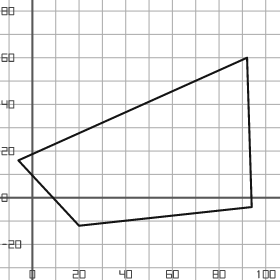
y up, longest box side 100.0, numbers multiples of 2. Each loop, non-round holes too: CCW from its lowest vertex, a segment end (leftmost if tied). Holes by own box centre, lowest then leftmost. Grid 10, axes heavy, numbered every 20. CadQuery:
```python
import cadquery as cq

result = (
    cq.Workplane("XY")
    .moveTo(20.0, -12.0)
    .lineTo(94.0, -4.0)
    .lineTo(92.0, 60.0)
    .lineTo(-6.0, 16.0)
    .close()
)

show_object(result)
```